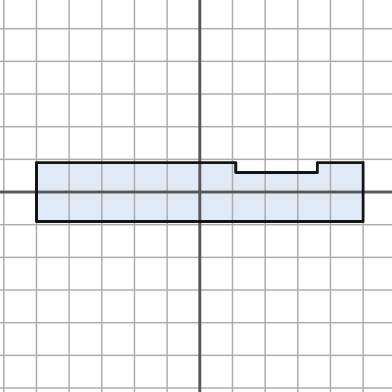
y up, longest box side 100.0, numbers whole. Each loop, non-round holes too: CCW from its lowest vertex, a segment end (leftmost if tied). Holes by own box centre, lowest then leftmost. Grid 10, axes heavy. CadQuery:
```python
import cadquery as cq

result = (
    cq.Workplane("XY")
    .moveTo(-50.0, -9.0)
    .lineTo(50.0, -9.0)
    .lineTo(50.0, 9.0)
    .lineTo(36.0, 9.0)
    .lineTo(36.0, 6.0)
    .lineTo(11.0, 6.0)
    .lineTo(11.0, 9.0)
    .lineTo(-50.0, 9.0)
    .close()
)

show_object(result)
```